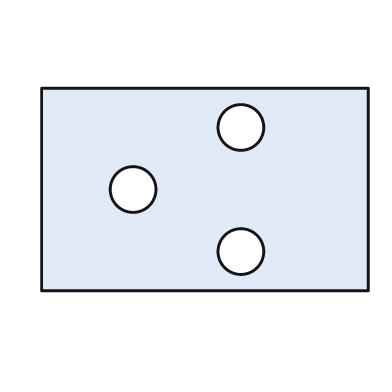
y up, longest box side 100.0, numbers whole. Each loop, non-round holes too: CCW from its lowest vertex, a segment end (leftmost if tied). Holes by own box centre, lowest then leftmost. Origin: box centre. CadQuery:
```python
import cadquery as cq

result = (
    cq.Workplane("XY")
    .moveTo(-50.0, -31.0)
    .lineTo(50.0, -31.0)
    .lineTo(50.0, 31.0)
    .lineTo(-50.0, 31.0)
    .close()
    .moveTo(11.0, -19.0)
    .circle(7.0)
    .moveTo(-22.0, 0.0)
    .circle(7.0)
    .moveTo(11.0, 19.0)
    .circle(7.0)
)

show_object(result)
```